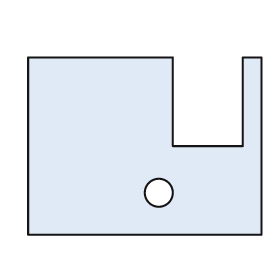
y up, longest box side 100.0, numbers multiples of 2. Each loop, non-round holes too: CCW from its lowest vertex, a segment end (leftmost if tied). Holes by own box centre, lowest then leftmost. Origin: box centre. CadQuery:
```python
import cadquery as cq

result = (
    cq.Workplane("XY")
    .moveTo(-50.0, -38.0)
    .lineTo(50.0, -38.0)
    .lineTo(50.0, 38.0)
    .lineTo(42.0, 38.0)
    .lineTo(42.0, 0.0)
    .lineTo(12.0, 0.0)
    .lineTo(12.0, 38.0)
    .lineTo(-50.0, 38.0)
    .close()
    .moveTo(6.0, -20.0)
    .circle(6.0)
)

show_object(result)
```